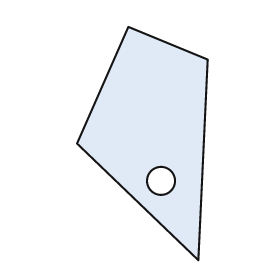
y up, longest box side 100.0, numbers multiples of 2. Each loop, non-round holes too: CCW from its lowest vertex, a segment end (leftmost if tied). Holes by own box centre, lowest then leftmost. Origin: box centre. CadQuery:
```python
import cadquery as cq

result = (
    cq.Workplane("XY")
    .moveTo(24.0, -50.0)
    .lineTo(28.0, 36.0)
    .lineTo(-6.0, 50.0)
    .lineTo(-28.0, 0.0)
    .close()
    .moveTo(8.0, -16.0)
    .circle(6.0)
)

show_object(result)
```